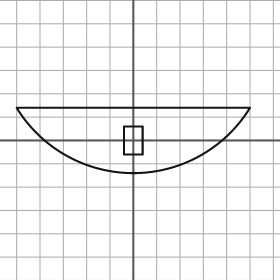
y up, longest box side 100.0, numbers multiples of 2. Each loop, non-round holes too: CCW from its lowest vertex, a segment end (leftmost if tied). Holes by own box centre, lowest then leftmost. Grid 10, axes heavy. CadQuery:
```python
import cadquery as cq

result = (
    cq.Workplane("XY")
    .moveTo(-50.0, 14.0)
    .threePointArc((0.0, -14.0), (50.0, 14.0))
    .close()
    .moveTo(-4.0, -6.0)
    .lineTo(4.0, -6.0)
    .lineTo(4.0, 6.0)
    .lineTo(-4.0, 6.0)
    .close()
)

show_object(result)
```